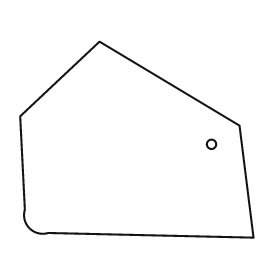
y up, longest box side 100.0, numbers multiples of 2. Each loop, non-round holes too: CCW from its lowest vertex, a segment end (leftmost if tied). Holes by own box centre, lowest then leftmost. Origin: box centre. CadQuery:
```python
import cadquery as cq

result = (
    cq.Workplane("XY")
    .moveTo(50.0, -42.0)
    .lineTo(44.0, 6.0)
    .lineTo(-16.0, 42.0)
    .lineTo(-50.0, 10.0)
    .lineTo(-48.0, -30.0)
    .threePointArc((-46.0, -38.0), (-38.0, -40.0))
    .close()
    .moveTo(32.0, -2.0)
    .circle(2.0)
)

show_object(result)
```